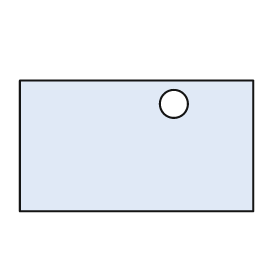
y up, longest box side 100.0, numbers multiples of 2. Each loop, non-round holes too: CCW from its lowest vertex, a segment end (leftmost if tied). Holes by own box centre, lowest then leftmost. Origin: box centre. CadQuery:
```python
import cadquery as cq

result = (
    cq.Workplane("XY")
    .moveTo(-50.0, -28.0)
    .lineTo(50.0, -28.0)
    .lineTo(50.0, 28.0)
    .lineTo(-50.0, 28.0)
    .close()
    .moveTo(16.0, 18.0)
    .circle(6.0)
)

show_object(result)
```